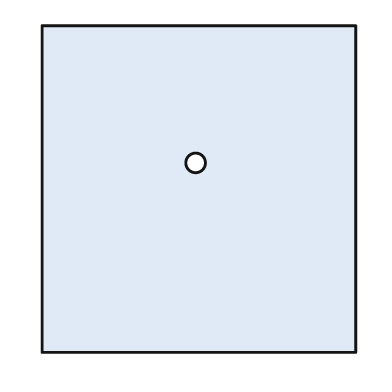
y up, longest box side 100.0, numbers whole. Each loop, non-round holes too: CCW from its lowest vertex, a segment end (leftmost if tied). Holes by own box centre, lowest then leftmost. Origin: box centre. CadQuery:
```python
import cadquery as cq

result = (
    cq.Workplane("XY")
    .moveTo(-48.0, -50.0)
    .lineTo(48.0, -50.0)
    .lineTo(48.0, 50.0)
    .lineTo(-48.0, 50.0)
    .close()
    .moveTo(-1.0, 8.0)
    .circle(3.0)
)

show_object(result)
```